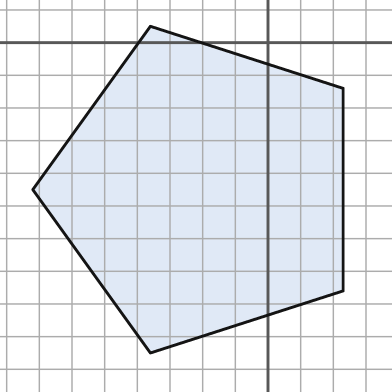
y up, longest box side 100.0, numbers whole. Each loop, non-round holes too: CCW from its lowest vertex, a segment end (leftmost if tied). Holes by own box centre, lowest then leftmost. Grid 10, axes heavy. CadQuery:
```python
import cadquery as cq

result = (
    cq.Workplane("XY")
    .moveTo(-36.0, -95.0)
    .lineTo(23.0, -76.0)
    .lineTo(23.0, -14.0)
    .lineTo(-36.0, 5.0)
    .lineTo(-72.0, -45.0)
    .close()
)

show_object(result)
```